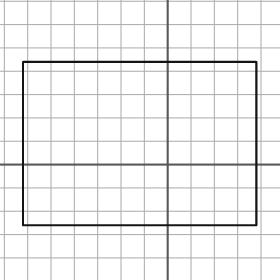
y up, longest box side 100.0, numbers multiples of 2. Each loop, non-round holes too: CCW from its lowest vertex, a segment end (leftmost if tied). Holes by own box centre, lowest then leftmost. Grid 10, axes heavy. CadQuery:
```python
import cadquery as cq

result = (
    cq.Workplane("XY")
    .moveTo(-62.0, -26.0)
    .lineTo(38.0, -26.0)
    .lineTo(38.0, 44.0)
    .lineTo(-62.0, 44.0)
    .close()
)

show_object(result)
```